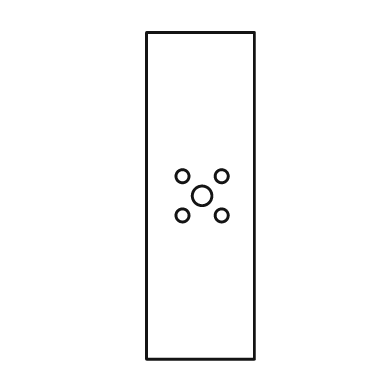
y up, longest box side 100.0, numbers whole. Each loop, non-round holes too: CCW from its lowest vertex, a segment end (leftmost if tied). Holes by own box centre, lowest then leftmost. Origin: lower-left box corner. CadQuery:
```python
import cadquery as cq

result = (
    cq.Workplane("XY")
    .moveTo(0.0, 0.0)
    .lineTo(33.0, 0.0)
    .lineTo(33.0, 100.0)
    .lineTo(0.0, 100.0)
    .close()
    .moveTo(11.0, 44.0)
    .circle(2.0)
    .moveTo(23.0, 44.0)
    .circle(2.0)
    .moveTo(17.0, 50.0)
    .circle(3.0)
    .moveTo(11.0, 56.0)
    .circle(2.0)
    .moveTo(23.0, 56.0)
    .circle(2.0)
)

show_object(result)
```